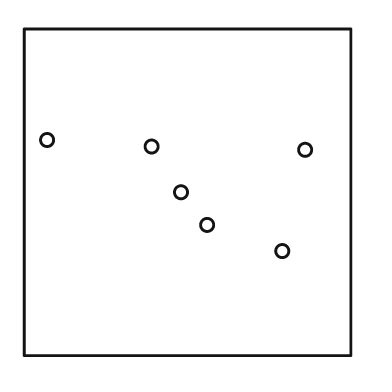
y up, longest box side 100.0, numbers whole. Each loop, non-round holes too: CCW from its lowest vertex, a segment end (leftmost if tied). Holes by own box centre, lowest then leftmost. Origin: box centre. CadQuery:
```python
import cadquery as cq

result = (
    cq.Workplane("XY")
    .moveTo(-50.0, -50.0)
    .lineTo(50.0, -50.0)
    .lineTo(50.0, 50.0)
    .lineTo(-50.0, 50.0)
    .close()
    .moveTo(29.0, -18.0)
    .circle(2.0)
    .moveTo(6.0, -10.0)
    .circle(2.0)
    .moveTo(-2.0, 0.0)
    .circle(2.0)
    .moveTo(36.0, 13.0)
    .circle(2.0)
    .moveTo(-11.0, 14.0)
    .circle(2.0)
    .moveTo(-43.0, 16.0)
    .circle(2.0)
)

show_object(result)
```